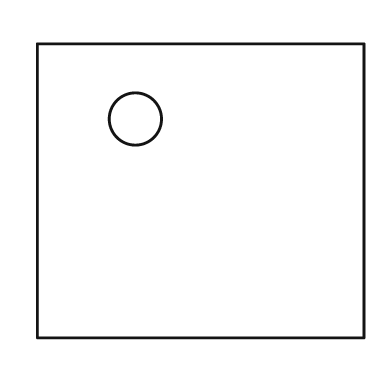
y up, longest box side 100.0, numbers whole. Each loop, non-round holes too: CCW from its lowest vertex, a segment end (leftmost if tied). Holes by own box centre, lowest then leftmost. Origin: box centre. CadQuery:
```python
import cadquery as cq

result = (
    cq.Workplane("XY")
    .moveTo(-50.0, -45.0)
    .lineTo(50.0, -45.0)
    .lineTo(50.0, 45.0)
    .lineTo(-50.0, 45.0)
    .close()
    .moveTo(-20.0, 22.0)
    .circle(8.0)
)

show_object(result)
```